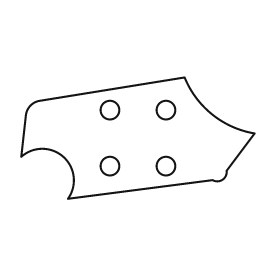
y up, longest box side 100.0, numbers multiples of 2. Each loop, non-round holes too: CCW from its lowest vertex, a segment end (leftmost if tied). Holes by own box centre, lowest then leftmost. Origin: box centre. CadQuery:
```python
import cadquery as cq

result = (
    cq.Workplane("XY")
    .moveTo(-30.0, -26.0)
    .lineTo(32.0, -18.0)
    .threePointArc((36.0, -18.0), (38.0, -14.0))
    .lineTo(50.0, 2.0)
    .threePointArc((32.0, 10.0), (20.0, 26.0))
    .lineTo(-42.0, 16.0)
    .threePointArc((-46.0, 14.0), (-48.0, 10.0))
    .lineTo(-50.0, -8.0)
    .threePointArc((-32.0, -8.0), (-30.0, -26.0))
    .close()
    .moveTo(-12.0, -12.0)
    .circle(4.0)
    .moveTo(12.0, -12.0)
    .circle(4.0)
    .moveTo(-12.0, 12.0)
    .circle(4.0)
    .moveTo(12.0, 12.0)
    .circle(4.0)
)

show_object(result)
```